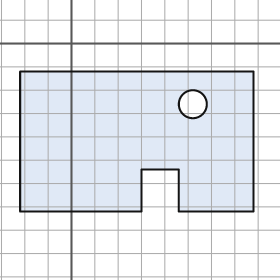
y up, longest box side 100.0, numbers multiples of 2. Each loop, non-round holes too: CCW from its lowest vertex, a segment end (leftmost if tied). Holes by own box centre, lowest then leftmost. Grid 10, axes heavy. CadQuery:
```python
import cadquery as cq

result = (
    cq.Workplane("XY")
    .moveTo(-22.0, -72.0)
    .lineTo(30.0, -72.0)
    .lineTo(30.0, -54.0)
    .lineTo(46.0, -54.0)
    .lineTo(46.0, -72.0)
    .lineTo(78.0, -72.0)
    .lineTo(78.0, -12.0)
    .lineTo(-22.0, -12.0)
    .close()
    .moveTo(52.0, -26.0)
    .circle(6.0)
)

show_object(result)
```